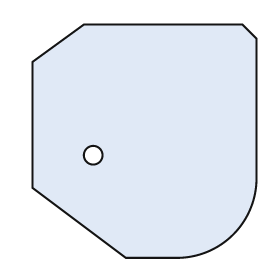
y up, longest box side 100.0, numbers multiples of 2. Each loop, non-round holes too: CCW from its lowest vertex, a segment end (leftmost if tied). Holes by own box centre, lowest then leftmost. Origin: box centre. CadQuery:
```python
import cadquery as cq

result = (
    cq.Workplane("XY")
    .moveTo(-8.0, -50.0)
    .lineTo(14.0, -50.0)
    .threePointArc((38.0, -40.0), (48.0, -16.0))
    .lineTo(48.0, 44.0)
    .lineTo(42.0, 50.0)
    .lineTo(-26.0, 50.0)
    .lineTo(-48.0, 34.0)
    .lineTo(-48.0, -20.0)
    .close()
    .moveTo(-22.0, -6.0)
    .circle(4.0)
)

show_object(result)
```